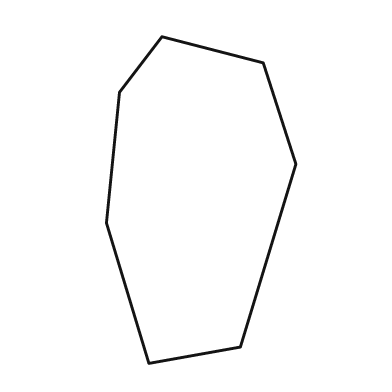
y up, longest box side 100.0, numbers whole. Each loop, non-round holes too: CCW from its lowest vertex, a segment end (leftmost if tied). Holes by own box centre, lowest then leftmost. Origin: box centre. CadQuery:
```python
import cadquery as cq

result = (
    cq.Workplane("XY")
    .moveTo(-16.0, -50.0)
    .lineTo(12.0, -45.0)
    .lineTo(29.0, 11.0)
    .lineTo(19.0, 42.0)
    .lineTo(-12.0, 50.0)
    .lineTo(-25.0, 33.0)
    .lineTo(-29.0, -7.0)
    .close()
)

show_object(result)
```